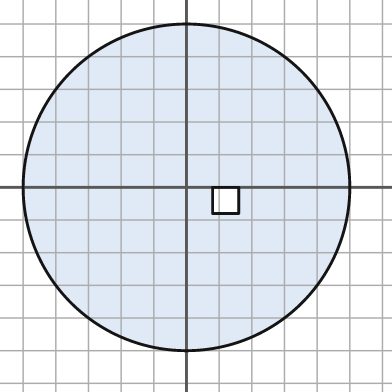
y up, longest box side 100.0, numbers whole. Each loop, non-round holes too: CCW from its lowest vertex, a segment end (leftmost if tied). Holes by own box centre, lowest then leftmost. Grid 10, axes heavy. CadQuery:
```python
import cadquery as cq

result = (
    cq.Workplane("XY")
    .moveTo(0.0, 0.0)
    .circle(50.0)
    .moveTo(8.0, -8.0)
    .lineTo(16.0, -8.0)
    .lineTo(16.0, 0.0)
    .lineTo(8.0, 0.0)
    .close()
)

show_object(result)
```